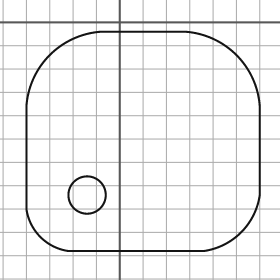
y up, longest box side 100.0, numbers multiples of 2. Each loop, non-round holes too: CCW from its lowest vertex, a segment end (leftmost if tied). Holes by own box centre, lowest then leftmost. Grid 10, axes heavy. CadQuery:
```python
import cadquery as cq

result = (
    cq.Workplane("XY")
    .moveTo(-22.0, -98.0)
    .lineTo(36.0, -98.0)
    .threePointArc((52.0, -90.0), (60.0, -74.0))
    .lineTo(60.0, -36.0)
    .threePointArc((50.0, -14.0), (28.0, -4.0))
    .lineTo(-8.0, -4.0)
    .threePointArc((-30.0, -14.0), (-40.0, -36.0))
    .lineTo(-40.0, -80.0)
    .threePointArc((-34.0, -92.0), (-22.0, -98.0))
    .close()
    .moveTo(-14.0, -74.0)
    .circle(8.0)
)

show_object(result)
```